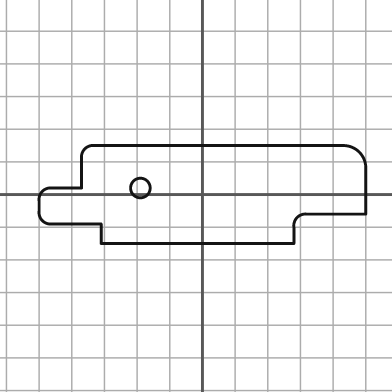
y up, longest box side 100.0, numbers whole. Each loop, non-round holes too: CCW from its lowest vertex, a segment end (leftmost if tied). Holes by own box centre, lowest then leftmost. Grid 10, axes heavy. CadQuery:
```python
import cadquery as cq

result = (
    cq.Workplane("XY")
    .moveTo(-31.0, -15.0)
    .lineTo(28.0, -15.0)
    .lineTo(28.0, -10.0)
    .threePointArc((29.0, -7.0), (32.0, -6.0))
    .lineTo(50.0, -6.0)
    .lineTo(50.0, 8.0)
    .threePointArc((48.0, 13.0), (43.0, 15.0))
    .lineTo(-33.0, 15.0)
    .threePointArc((-36.0, 14.0), (-37.0, 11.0))
    .lineTo(-37.0, 2.0)
    .lineTo(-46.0, 2.0)
    .threePointArc((-49.0, 1.0), (-50.0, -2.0))
    .lineTo(-50.0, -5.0)
    .threePointArc((-49.0, -8.0), (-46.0, -9.0))
    .lineTo(-31.0, -9.0)
    .close()
    .moveTo(-19.0, 2.0)
    .circle(3.0)
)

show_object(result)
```